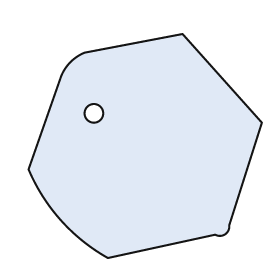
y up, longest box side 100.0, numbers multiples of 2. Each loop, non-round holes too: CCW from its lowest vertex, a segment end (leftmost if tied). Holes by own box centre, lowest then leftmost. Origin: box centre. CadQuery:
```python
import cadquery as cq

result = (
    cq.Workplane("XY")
    .moveTo(-16.0, -48.0)
    .lineTo(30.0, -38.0)
    .threePointArc((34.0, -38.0), (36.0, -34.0))
    .lineTo(50.0, 10.0)
    .lineTo(16.0, 48.0)
    .lineTo(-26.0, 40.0)
    .threePointArc((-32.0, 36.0), (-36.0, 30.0))
    .lineTo(-50.0, -10.0)
    .threePointArc((-36.0, -32.0), (-16.0, -48.0))
    .close()
    .moveTo(-22.0, 14.0)
    .circle(4.0)
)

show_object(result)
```